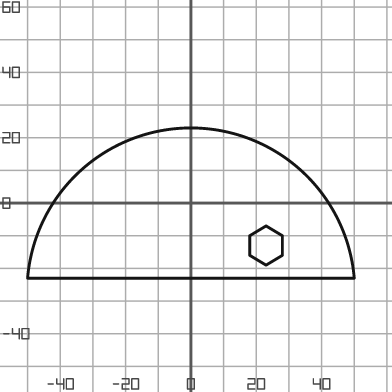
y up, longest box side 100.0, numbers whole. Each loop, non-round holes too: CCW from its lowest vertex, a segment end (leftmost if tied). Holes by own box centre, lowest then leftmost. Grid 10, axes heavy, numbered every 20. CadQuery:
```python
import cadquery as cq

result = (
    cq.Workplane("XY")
    .moveTo(-50.0, -23.0)
    .lineTo(50.0, -23.0)
    .threePointArc((0.0, 23.0), (-50.0, -23.0))
    .close()
    .moveTo(23.0, -19.0)
    .lineTo(28.0, -16.0)
    .lineTo(28.0, -10.0)
    .lineTo(23.0, -7.0)
    .lineTo(18.0, -10.0)
    .lineTo(18.0, -16.0)
    .close()
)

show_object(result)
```